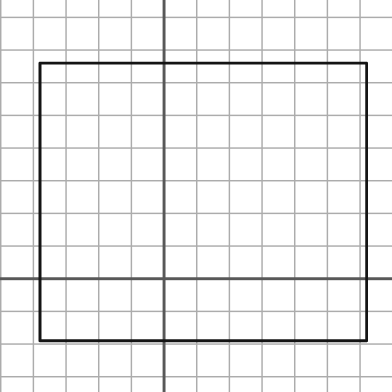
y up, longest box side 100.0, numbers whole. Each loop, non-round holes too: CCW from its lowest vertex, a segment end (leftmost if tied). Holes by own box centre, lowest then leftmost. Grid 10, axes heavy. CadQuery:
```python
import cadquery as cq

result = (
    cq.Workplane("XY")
    .moveTo(-38.0, -19.0)
    .lineTo(62.0, -19.0)
    .lineTo(62.0, 66.0)
    .lineTo(-38.0, 66.0)
    .close()
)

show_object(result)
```